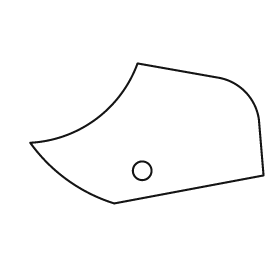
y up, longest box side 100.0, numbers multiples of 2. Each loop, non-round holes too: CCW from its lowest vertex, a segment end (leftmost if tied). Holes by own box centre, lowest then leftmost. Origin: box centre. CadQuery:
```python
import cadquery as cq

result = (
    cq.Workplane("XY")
    .moveTo(-14.0, -30.0)
    .lineTo(50.0, -18.0)
    .lineTo(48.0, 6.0)
    .threePointArc((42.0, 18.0), (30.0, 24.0))
    .lineTo(-4.0, 30.0)
    .threePointArc((-22.0, 6.0), (-50.0, -4.0))
    .threePointArc((-34.0, -20.0), (-14.0, -30.0))
    .close()
    .moveTo(-2.0, -16.0)
    .circle(4.0)
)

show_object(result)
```